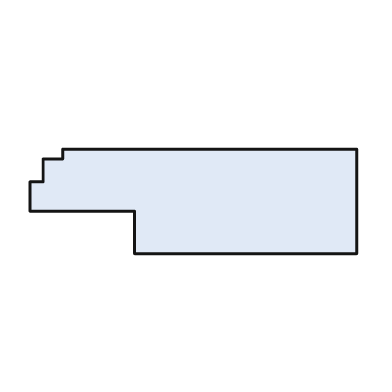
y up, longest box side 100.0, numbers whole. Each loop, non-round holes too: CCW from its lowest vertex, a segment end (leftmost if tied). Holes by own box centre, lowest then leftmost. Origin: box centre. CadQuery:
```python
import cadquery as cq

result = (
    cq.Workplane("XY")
    .moveTo(-18.0, -16.0)
    .lineTo(50.0, -16.0)
    .lineTo(50.0, 16.0)
    .lineTo(-40.0, 16.0)
    .lineTo(-40.0, 13.0)
    .lineTo(-46.0, 13.0)
    .lineTo(-46.0, 6.0)
    .lineTo(-50.0, 6.0)
    .lineTo(-50.0, -3.0)
    .lineTo(-18.0, -3.0)
    .close()
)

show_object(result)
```